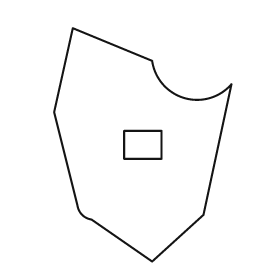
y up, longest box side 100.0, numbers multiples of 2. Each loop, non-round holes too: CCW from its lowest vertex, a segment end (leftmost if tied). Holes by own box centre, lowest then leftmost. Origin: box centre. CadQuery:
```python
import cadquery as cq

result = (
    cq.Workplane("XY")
    .moveTo(4.0, -50.0)
    .lineTo(26.0, -30.0)
    .lineTo(38.0, 26.0)
    .threePointArc((18.0, 20.0), (4.0, 36.0))
    .lineTo(-30.0, 50.0)
    .lineTo(-38.0, 14.0)
    .lineTo(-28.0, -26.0)
    .threePointArc((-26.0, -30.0), (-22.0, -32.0))
    .close()
    .moveTo(-8.0, -6.0)
    .lineTo(8.0, -6.0)
    .lineTo(8.0, 6.0)
    .lineTo(-8.0, 6.0)
    .close()
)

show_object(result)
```